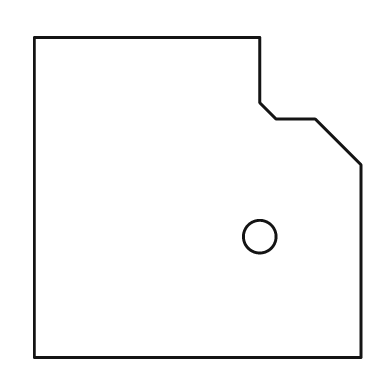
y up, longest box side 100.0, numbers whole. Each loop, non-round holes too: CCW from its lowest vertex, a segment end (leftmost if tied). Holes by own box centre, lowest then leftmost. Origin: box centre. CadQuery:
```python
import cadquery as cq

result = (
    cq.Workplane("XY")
    .moveTo(-50.0, -49.0)
    .lineTo(50.0, -49.0)
    .lineTo(50.0, 10.0)
    .lineTo(36.0, 24.0)
    .lineTo(24.0, 24.0)
    .lineTo(19.0, 29.0)
    .lineTo(19.0, 49.0)
    .lineTo(-50.0, 49.0)
    .close()
    .moveTo(19.0, -12.0)
    .circle(5.0)
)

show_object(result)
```